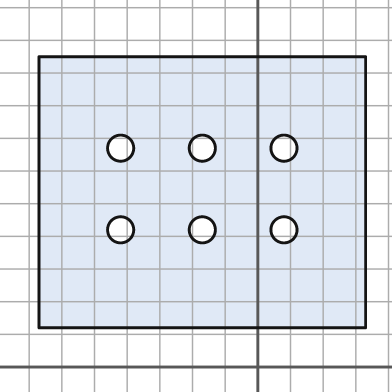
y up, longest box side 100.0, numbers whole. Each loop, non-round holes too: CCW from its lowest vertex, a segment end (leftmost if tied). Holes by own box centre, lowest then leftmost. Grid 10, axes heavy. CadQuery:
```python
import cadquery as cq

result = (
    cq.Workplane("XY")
    .moveTo(-67.0, 12.0)
    .lineTo(33.0, 12.0)
    .lineTo(33.0, 95.0)
    .lineTo(-67.0, 95.0)
    .close()
    .moveTo(-42.0, 42.0)
    .circle(4.0)
    .moveTo(-17.0, 42.0)
    .circle(4.0)
    .moveTo(8.0, 42.0)
    .circle(4.0)
    .moveTo(-42.0, 67.0)
    .circle(4.0)
    .moveTo(-17.0, 67.0)
    .circle(4.0)
    .moveTo(8.0, 67.0)
    .circle(4.0)
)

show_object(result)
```